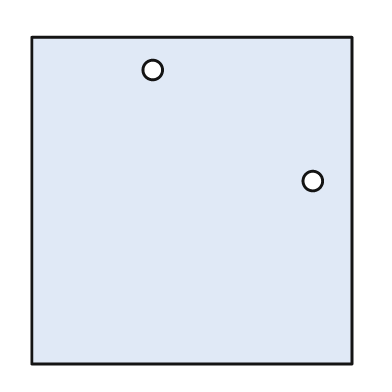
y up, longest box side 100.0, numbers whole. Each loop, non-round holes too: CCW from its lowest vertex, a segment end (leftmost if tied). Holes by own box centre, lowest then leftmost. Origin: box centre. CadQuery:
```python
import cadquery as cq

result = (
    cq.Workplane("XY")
    .moveTo(-49.0, -50.0)
    .lineTo(49.0, -50.0)
    .lineTo(49.0, 50.0)
    .lineTo(-49.0, 50.0)
    .close()
    .moveTo(37.0, 6.0)
    .circle(3.0)
    .moveTo(-12.0, 40.0)
    .circle(3.0)
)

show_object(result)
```